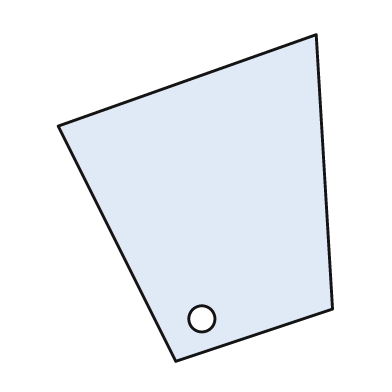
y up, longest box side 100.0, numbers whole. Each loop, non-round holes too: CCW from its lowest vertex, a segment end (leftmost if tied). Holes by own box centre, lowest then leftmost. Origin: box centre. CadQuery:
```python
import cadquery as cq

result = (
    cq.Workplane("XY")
    .moveTo(-6.0, -50.0)
    .lineTo(42.0, -34.0)
    .lineTo(37.0, 50.0)
    .lineTo(-42.0, 22.0)
    .close()
    .moveTo(2.0, -37.0)
    .circle(4.0)
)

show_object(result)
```